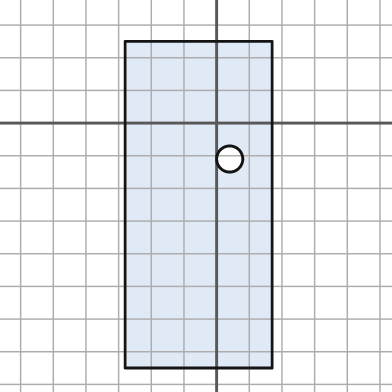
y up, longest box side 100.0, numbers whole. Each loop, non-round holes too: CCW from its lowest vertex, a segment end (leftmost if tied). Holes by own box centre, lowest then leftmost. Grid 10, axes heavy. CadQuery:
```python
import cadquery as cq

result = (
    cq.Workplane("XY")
    .moveTo(-28.0, -75.0)
    .lineTo(17.0, -75.0)
    .lineTo(17.0, 25.0)
    .lineTo(-28.0, 25.0)
    .close()
    .moveTo(4.0, -11.0)
    .circle(4.0)
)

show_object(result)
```